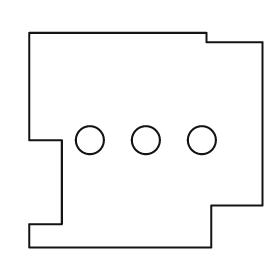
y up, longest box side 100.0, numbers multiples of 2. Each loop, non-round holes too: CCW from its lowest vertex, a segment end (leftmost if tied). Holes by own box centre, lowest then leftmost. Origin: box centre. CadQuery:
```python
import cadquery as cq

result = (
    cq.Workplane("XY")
    .moveTo(-50.0, -46.0)
    .lineTo(28.0, -46.0)
    .lineTo(28.0, -28.0)
    .lineTo(50.0, -28.0)
    .lineTo(50.0, 42.0)
    .lineTo(26.0, 42.0)
    .lineTo(26.0, 46.0)
    .lineTo(-50.0, 46.0)
    .lineTo(-50.0, 0.0)
    .lineTo(-36.0, 0.0)
    .lineTo(-36.0, -36.0)
    .lineTo(-50.0, -36.0)
    .close()
    .moveTo(-24.0, 0.0)
    .circle(6.0)
    .moveTo(0.0, 0.0)
    .circle(6.0)
    .moveTo(24.0, 0.0)
    .circle(6.0)
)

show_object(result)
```